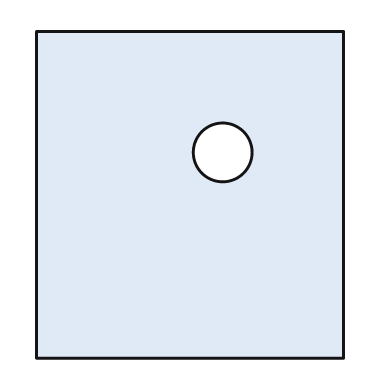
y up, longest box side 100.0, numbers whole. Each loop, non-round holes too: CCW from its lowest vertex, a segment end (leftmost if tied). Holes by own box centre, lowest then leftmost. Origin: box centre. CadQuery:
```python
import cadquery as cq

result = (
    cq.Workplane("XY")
    .moveTo(-47.0, -50.0)
    .lineTo(47.0, -50.0)
    .lineTo(47.0, 50.0)
    .lineTo(-47.0, 50.0)
    .close()
    .moveTo(10.0, 13.0)
    .circle(9.0)
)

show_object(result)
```